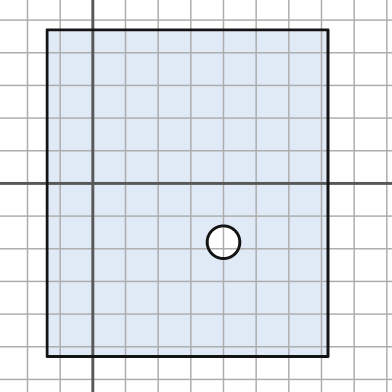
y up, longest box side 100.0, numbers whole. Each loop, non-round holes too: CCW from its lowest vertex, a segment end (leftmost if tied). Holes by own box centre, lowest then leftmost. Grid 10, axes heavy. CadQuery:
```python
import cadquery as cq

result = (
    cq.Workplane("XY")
    .moveTo(-14.0, -53.0)
    .lineTo(72.0, -53.0)
    .lineTo(72.0, 47.0)
    .lineTo(-14.0, 47.0)
    .close()
    .moveTo(40.0, -18.0)
    .circle(5.0)
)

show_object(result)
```